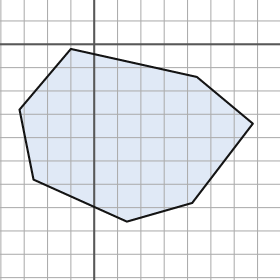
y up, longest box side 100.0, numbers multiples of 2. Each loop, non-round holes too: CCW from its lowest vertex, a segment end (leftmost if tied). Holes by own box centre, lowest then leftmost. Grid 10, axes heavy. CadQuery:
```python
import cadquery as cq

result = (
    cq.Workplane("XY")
    .moveTo(14.0, -76.0)
    .lineTo(42.0, -68.0)
    .lineTo(68.0, -34.0)
    .lineTo(44.0, -14.0)
    .lineTo(-10.0, -2.0)
    .lineTo(-32.0, -28.0)
    .lineTo(-26.0, -58.0)
    .close()
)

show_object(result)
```